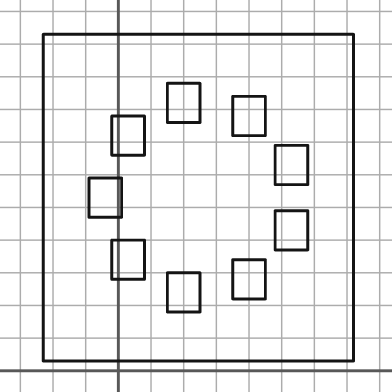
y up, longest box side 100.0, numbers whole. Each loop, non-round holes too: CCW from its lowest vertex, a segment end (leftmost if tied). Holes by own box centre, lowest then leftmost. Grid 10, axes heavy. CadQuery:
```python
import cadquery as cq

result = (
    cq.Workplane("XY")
    .moveTo(-23.0, 3.0)
    .lineTo(72.0, 3.0)
    .lineTo(72.0, 103.0)
    .lineTo(-23.0, 103.0)
    .close()
    .moveTo(15.0, 18.0)
    .lineTo(25.0, 18.0)
    .lineTo(25.0, 30.0)
    .lineTo(15.0, 30.0)
    .close()
    .moveTo(35.0, 22.0)
    .lineTo(45.0, 22.0)
    .lineTo(45.0, 34.0)
    .lineTo(35.0, 34.0)
    .close()
    .moveTo(-2.0, 28.0)
    .lineTo(8.0, 28.0)
    .lineTo(8.0, 40.0)
    .lineTo(-2.0, 40.0)
    .close()
    .moveTo(48.0, 37.0)
    .lineTo(58.0, 37.0)
    .lineTo(58.0, 49.0)
    .lineTo(48.0, 49.0)
    .close()
    .moveTo(-9.0, 47.0)
    .lineTo(1.0, 47.0)
    .lineTo(1.0, 59.0)
    .lineTo(-9.0, 59.0)
    .close()
    .moveTo(48.0, 57.0)
    .lineTo(58.0, 57.0)
    .lineTo(58.0, 69.0)
    .lineTo(48.0, 69.0)
    .close()
    .moveTo(-2.0, 66.0)
    .lineTo(8.0, 66.0)
    .lineTo(8.0, 78.0)
    .lineTo(-2.0, 78.0)
    .close()
    .moveTo(35.0, 72.0)
    .lineTo(45.0, 72.0)
    .lineTo(45.0, 84.0)
    .lineTo(35.0, 84.0)
    .close()
    .moveTo(15.0, 76.0)
    .lineTo(25.0, 76.0)
    .lineTo(25.0, 88.0)
    .lineTo(15.0, 88.0)
    .close()
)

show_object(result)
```